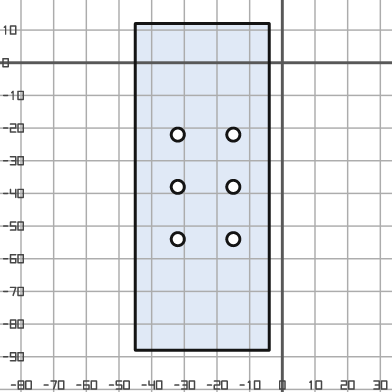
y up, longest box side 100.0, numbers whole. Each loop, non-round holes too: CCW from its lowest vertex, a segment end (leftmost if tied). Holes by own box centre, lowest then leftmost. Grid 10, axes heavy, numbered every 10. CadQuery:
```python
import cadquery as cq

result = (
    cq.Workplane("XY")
    .moveTo(-45.0, -88.0)
    .lineTo(-4.0, -88.0)
    .lineTo(-4.0, 12.0)
    .lineTo(-45.0, 12.0)
    .close()
    .moveTo(-32.0, -54.0)
    .circle(2.0)
    .moveTo(-15.0, -54.0)
    .circle(2.0)
    .moveTo(-32.0, -38.0)
    .circle(2.0)
    .moveTo(-15.0, -38.0)
    .circle(2.0)
    .moveTo(-32.0, -22.0)
    .circle(2.0)
    .moveTo(-15.0, -22.0)
    .circle(2.0)
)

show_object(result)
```